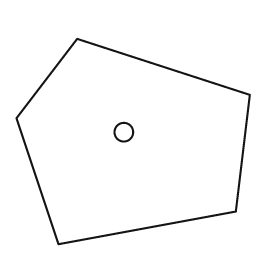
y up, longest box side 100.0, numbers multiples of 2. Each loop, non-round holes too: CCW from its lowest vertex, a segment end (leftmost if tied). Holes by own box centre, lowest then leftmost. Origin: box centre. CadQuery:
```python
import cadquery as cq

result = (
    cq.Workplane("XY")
    .moveTo(-32.0, -44.0)
    .lineTo(44.0, -30.0)
    .lineTo(50.0, 20.0)
    .lineTo(-24.0, 44.0)
    .lineTo(-50.0, 10.0)
    .close()
    .moveTo(-4.0, 4.0)
    .circle(4.0)
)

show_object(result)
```